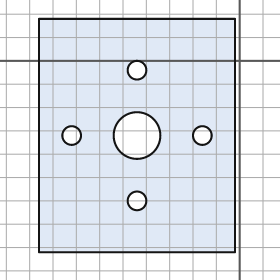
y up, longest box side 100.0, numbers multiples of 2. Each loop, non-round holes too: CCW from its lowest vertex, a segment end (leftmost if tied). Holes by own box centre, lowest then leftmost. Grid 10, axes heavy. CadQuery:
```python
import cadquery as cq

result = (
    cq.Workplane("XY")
    .moveTo(-86.0, -82.0)
    .lineTo(-2.0, -82.0)
    .lineTo(-2.0, 18.0)
    .lineTo(-86.0, 18.0)
    .close()
    .moveTo(-44.0, -60.0)
    .circle(4.0)
    .moveTo(-72.0, -32.0)
    .circle(4.0)
    .moveTo(-44.0, -32.0)
    .circle(10.0)
    .moveTo(-16.0, -32.0)
    .circle(4.0)
    .moveTo(-44.0, -4.0)
    .circle(4.0)
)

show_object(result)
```